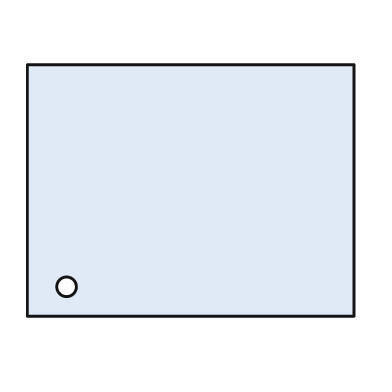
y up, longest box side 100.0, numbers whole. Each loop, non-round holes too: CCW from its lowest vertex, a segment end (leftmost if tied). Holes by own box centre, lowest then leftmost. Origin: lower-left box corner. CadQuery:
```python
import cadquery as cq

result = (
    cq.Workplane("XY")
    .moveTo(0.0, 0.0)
    .lineTo(100.0, 0.0)
    .lineTo(100.0, 77.0)
    .lineTo(0.0, 77.0)
    .close()
    .moveTo(12.0, 9.0)
    .circle(3.0)
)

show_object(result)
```